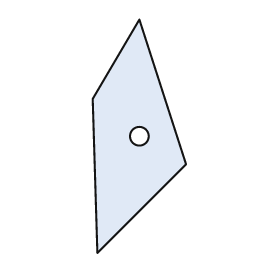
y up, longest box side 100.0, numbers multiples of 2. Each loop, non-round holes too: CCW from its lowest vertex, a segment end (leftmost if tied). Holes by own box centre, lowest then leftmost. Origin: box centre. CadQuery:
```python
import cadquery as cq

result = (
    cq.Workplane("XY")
    .moveTo(-18.0, -50.0)
    .lineTo(20.0, -12.0)
    .lineTo(0.0, 50.0)
    .lineTo(-20.0, 16.0)
    .close()
    .moveTo(0.0, 0.0)
    .circle(4.0)
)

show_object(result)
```